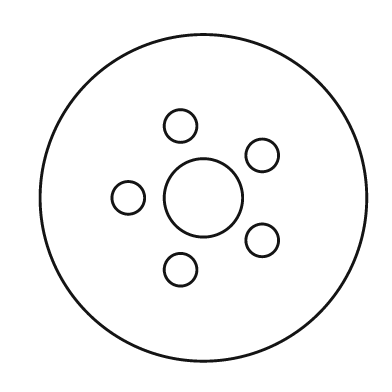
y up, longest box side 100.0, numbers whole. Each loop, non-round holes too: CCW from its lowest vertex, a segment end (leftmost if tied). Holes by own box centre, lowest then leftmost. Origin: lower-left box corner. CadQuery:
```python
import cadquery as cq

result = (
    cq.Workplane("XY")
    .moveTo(50.0, 50.0)
    .circle(50.0)
    .moveTo(43.0, 28.0)
    .circle(5.0)
    .moveTo(68.0, 37.0)
    .circle(5.0)
    .moveTo(27.0, 50.0)
    .circle(5.0)
    .moveTo(50.0, 50.0)
    .circle(12.0)
    .moveTo(68.0, 63.0)
    .circle(5.0)
    .moveTo(43.0, 72.0)
    .circle(5.0)
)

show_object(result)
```